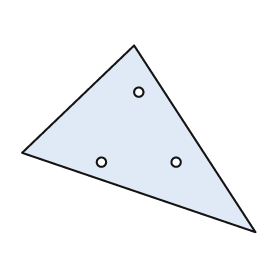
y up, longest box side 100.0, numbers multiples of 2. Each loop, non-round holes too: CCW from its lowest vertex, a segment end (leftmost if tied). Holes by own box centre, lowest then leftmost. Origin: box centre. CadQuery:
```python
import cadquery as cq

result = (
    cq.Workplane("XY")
    .moveTo(50.0, -40.0)
    .lineTo(-2.0, 40.0)
    .lineTo(-50.0, -6.0)
    .close()
    .moveTo(-16.0, -10.0)
    .circle(2.0)
    .moveTo(16.0, -10.0)
    .circle(2.0)
    .moveTo(0.0, 20.0)
    .circle(2.0)
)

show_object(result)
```